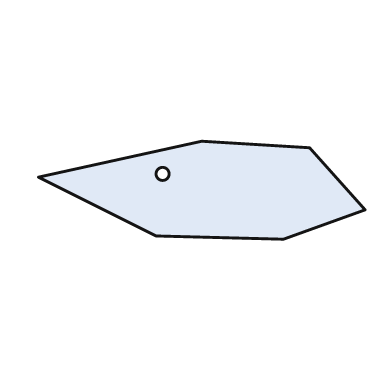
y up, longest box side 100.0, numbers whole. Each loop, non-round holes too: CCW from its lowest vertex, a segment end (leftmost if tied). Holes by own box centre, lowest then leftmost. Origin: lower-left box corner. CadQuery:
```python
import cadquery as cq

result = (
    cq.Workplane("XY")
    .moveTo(75.0, 0.0)
    .lineTo(100.0, 9.0)
    .lineTo(83.0, 28.0)
    .lineTo(50.0, 30.0)
    .lineTo(0.0, 19.0)
    .lineTo(36.0, 1.0)
    .close()
    .moveTo(38.0, 20.0)
    .circle(2.0)
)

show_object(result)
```